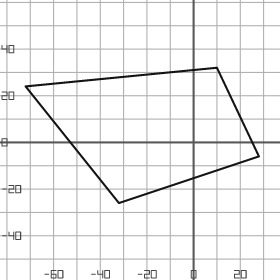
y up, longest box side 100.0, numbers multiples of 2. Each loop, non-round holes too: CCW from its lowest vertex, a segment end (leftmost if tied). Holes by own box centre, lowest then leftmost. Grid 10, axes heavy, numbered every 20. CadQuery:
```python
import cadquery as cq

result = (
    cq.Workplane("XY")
    .moveTo(-32.0, -26.0)
    .lineTo(28.0, -6.0)
    .lineTo(10.0, 32.0)
    .lineTo(-72.0, 24.0)
    .close()
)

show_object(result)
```